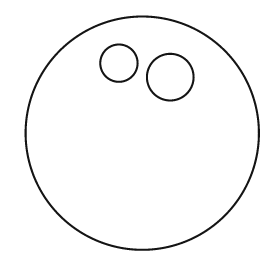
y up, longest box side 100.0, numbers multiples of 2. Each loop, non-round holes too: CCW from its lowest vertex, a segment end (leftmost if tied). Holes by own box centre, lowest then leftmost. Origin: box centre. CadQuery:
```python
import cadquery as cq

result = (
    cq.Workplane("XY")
    .moveTo(0.0, 0.0)
    .circle(50.0)
    .moveTo(12.0, 24.0)
    .circle(10.0)
    .moveTo(-10.0, 30.0)
    .circle(8.0)
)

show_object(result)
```